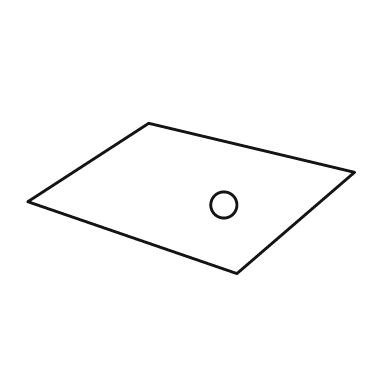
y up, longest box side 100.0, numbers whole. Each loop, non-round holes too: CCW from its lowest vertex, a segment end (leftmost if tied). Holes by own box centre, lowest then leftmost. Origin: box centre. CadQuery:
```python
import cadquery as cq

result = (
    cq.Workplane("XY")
    .moveTo(14.0, -23.0)
    .lineTo(50.0, 8.0)
    .lineTo(-13.0, 23.0)
    .lineTo(-50.0, -1.0)
    .close()
    .moveTo(10.0, -2.0)
    .circle(4.0)
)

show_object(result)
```